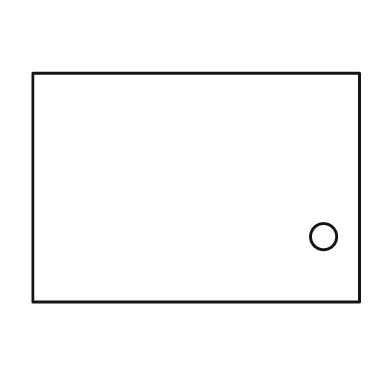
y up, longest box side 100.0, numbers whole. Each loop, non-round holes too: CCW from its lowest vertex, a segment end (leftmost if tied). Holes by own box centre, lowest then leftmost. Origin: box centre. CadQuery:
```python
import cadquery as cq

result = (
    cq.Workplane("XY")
    .moveTo(-50.0, -35.0)
    .lineTo(50.0, -35.0)
    .lineTo(50.0, 35.0)
    .lineTo(-50.0, 35.0)
    .close()
    .moveTo(39.0, -15.0)
    .circle(4.0)
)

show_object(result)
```